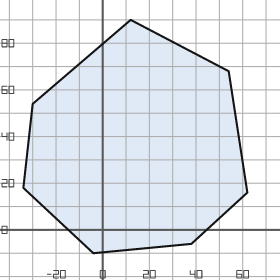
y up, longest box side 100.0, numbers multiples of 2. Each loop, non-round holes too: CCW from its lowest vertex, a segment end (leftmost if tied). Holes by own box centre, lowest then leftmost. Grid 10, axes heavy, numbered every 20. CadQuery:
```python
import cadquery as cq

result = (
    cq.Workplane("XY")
    .moveTo(-4.0, -10.0)
    .lineTo(38.0, -6.0)
    .lineTo(62.0, 16.0)
    .lineTo(54.0, 68.0)
    .lineTo(12.0, 90.0)
    .lineTo(-30.0, 54.0)
    .lineTo(-34.0, 18.0)
    .close()
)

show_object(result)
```